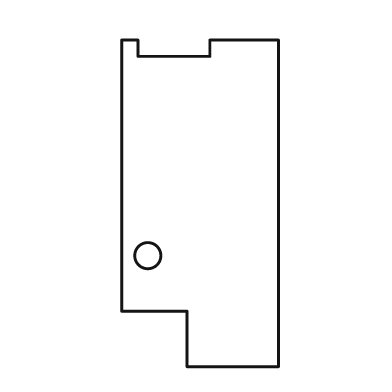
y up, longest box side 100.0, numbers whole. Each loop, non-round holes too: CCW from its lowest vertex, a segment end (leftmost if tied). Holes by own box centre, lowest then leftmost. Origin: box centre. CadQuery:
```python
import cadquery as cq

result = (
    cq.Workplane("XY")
    .moveTo(-4.0, -50.0)
    .lineTo(24.0, -50.0)
    .lineTo(24.0, 50.0)
    .lineTo(3.0, 50.0)
    .lineTo(3.0, 45.0)
    .lineTo(-19.0, 45.0)
    .lineTo(-19.0, 50.0)
    .lineTo(-24.0, 50.0)
    .lineTo(-24.0, -33.0)
    .lineTo(-4.0, -33.0)
    .close()
    .moveTo(-16.0, -16.0)
    .circle(4.0)
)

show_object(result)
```